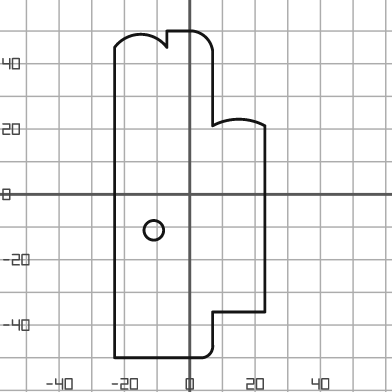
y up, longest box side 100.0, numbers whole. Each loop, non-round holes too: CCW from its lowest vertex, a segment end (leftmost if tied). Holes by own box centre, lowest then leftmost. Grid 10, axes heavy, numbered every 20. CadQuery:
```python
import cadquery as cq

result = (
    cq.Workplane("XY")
    .moveTo(-23.0, -50.0)
    .lineTo(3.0, -50.0)
    .threePointArc((6.0, -49.0), (7.0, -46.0))
    .lineTo(7.0, -36.0)
    .lineTo(23.0, -36.0)
    .lineTo(23.0, 21.0)
    .threePointArc((15.0, 23.0), (7.0, 21.0))
    .lineTo(7.0, 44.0)
    .threePointArc((5.0, 48.0), (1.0, 50.0))
    .lineTo(-7.0, 50.0)
    .lineTo(-7.0, 45.0)
    .threePointArc((-15.0, 49.0), (-23.0, 45.0))
    .close()
    .moveTo(-11.0, -11.0)
    .circle(3.0)
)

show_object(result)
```